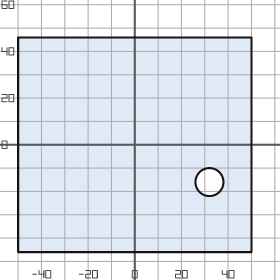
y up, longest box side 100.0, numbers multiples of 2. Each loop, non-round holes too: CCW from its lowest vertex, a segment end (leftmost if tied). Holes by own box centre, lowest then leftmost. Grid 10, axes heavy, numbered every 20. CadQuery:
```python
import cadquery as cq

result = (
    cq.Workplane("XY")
    .moveTo(-50.0, -46.0)
    .lineTo(50.0, -46.0)
    .lineTo(50.0, 46.0)
    .lineTo(-50.0, 46.0)
    .close()
    .moveTo(32.0, -16.0)
    .circle(6.0)
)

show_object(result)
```